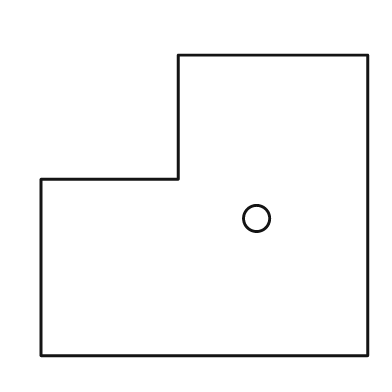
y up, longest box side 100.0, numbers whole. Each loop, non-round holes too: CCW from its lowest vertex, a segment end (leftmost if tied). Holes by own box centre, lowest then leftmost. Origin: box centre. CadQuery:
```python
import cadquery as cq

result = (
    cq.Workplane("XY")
    .moveTo(-50.0, -46.0)
    .lineTo(50.0, -46.0)
    .lineTo(50.0, 46.0)
    .lineTo(-8.0, 46.0)
    .lineTo(-8.0, 8.0)
    .lineTo(-50.0, 8.0)
    .close()
    .moveTo(16.0, -4.0)
    .circle(4.0)
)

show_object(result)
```